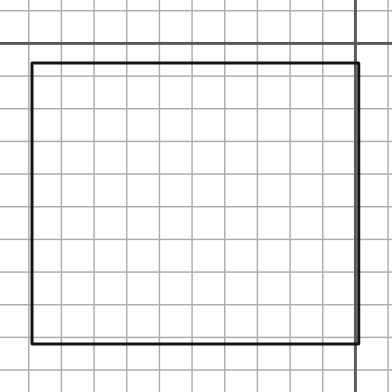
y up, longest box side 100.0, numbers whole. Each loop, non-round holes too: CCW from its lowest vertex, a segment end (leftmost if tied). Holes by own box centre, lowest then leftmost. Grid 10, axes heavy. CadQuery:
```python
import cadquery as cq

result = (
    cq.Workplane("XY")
    .moveTo(-99.0, -92.0)
    .lineTo(1.0, -92.0)
    .lineTo(1.0, -6.0)
    .lineTo(-99.0, -6.0)
    .close()
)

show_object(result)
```